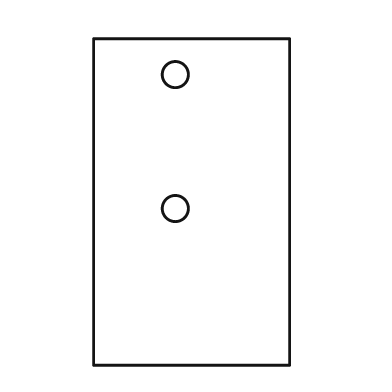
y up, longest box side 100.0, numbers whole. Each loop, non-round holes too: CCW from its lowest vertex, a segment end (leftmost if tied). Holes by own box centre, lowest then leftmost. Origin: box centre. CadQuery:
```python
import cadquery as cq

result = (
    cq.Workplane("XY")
    .moveTo(-30.0, -50.0)
    .lineTo(30.0, -50.0)
    .lineTo(30.0, 50.0)
    .lineTo(-30.0, 50.0)
    .close()
    .moveTo(-5.0, -2.0)
    .circle(4.0)
    .moveTo(-5.0, 39.0)
    .circle(4.0)
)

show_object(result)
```